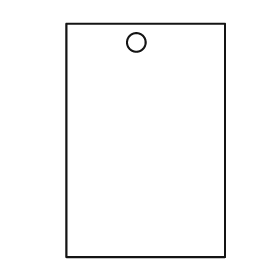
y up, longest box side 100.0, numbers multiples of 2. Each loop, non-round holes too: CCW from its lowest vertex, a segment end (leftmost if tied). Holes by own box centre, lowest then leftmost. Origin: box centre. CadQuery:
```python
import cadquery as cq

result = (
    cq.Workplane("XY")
    .moveTo(-34.0, -50.0)
    .lineTo(34.0, -50.0)
    .lineTo(34.0, 50.0)
    .lineTo(-34.0, 50.0)
    .close()
    .moveTo(-4.0, 42.0)
    .circle(4.0)
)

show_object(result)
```